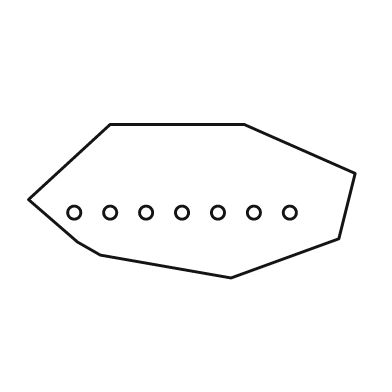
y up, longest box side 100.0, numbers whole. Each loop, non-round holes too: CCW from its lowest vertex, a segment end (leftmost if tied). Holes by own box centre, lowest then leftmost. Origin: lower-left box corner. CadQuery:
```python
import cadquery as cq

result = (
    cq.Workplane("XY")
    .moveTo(62.0, 0.0)
    .lineTo(95.0, 12.0)
    .lineTo(100.0, 32.0)
    .lineTo(66.0, 47.0)
    .lineTo(25.0, 47.0)
    .lineTo(0.0, 24.0)
    .lineTo(15.0, 11.0)
    .lineTo(22.0, 7.0)
    .close()
    .moveTo(14.0, 20.0)
    .circle(2.0)
    .moveTo(25.0, 20.0)
    .circle(2.0)
    .moveTo(36.0, 20.0)
    .circle(2.0)
    .moveTo(47.0, 20.0)
    .circle(2.0)
    .moveTo(58.0, 20.0)
    .circle(2.0)
    .moveTo(69.0, 20.0)
    .circle(2.0)
    .moveTo(80.0, 20.0)
    .circle(2.0)
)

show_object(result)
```